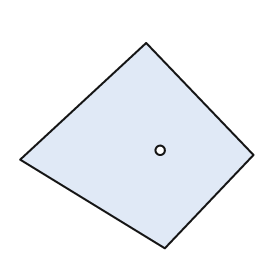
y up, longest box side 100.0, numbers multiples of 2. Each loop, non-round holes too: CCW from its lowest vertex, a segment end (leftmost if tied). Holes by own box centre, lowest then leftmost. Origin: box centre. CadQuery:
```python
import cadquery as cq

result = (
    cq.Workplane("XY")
    .moveTo(12.0, -44.0)
    .lineTo(50.0, -4.0)
    .lineTo(4.0, 44.0)
    .lineTo(-50.0, -6.0)
    .close()
    .moveTo(10.0, -2.0)
    .circle(2.0)
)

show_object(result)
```